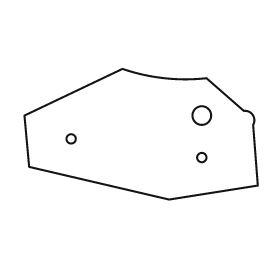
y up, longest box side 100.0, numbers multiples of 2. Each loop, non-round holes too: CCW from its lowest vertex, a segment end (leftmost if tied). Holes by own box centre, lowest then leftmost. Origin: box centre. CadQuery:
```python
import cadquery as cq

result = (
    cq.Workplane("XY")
    .moveTo(12.0, -28.0)
    .lineTo(50.0, -22.0)
    .lineTo(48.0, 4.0)
    .threePointArc((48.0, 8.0), (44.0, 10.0))
    .lineTo(28.0, 24.0)
    .threePointArc((10.0, 24.0), (-8.0, 28.0))
    .lineTo(-50.0, 8.0)
    .lineTo(-48.0, -14.0)
    .close()
    .moveTo(26.0, -10.0)
    .circle(2.0)
    .moveTo(-30.0, -2.0)
    .circle(2.0)
    .moveTo(26.0, 8.0)
    .circle(4.0)
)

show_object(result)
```